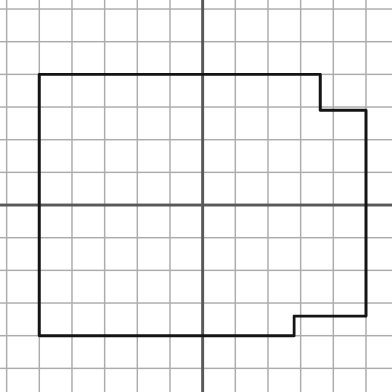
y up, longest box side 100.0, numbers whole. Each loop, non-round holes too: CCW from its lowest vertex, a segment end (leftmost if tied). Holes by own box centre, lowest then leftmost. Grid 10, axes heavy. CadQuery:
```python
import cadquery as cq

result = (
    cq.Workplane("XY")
    .moveTo(-50.0, -40.0)
    .lineTo(28.0, -40.0)
    .lineTo(28.0, -34.0)
    .lineTo(50.0, -34.0)
    .lineTo(50.0, 29.0)
    .lineTo(36.0, 29.0)
    .lineTo(36.0, 40.0)
    .lineTo(-50.0, 40.0)
    .close()
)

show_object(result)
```